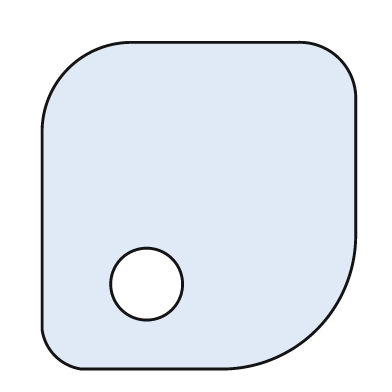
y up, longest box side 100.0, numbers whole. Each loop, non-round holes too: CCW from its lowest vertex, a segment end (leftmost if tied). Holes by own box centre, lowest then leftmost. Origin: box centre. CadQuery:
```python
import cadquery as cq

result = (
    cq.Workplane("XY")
    .moveTo(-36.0, -50.0)
    .lineTo(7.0, -50.0)
    .threePointArc((36.0, -38.0), (48.0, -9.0))
    .lineTo(48.0, 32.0)
    .threePointArc((43.0, 45.0), (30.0, 50.0))
    .lineTo(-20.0, 50.0)
    .threePointArc((-40.0, 42.0), (-48.0, 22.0))
    .lineTo(-48.0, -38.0)
    .threePointArc((-44.0, -46.0), (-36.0, -50.0))
    .close()
    .moveTo(-16.0, -24.0)
    .circle(11.0)
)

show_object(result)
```